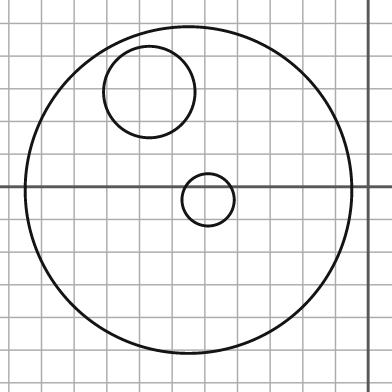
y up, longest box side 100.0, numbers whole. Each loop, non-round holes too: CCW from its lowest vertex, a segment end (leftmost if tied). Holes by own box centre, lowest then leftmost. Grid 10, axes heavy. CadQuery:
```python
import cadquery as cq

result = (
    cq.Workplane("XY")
    .moveTo(-55.0, -1.0)
    .circle(50.0)
    .moveTo(-49.0, -4.0)
    .circle(8.0)
    .moveTo(-67.0, 29.0)
    .circle(14.0)
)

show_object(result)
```